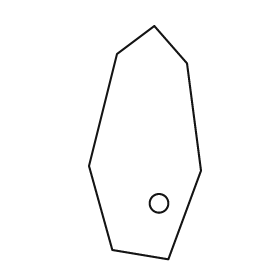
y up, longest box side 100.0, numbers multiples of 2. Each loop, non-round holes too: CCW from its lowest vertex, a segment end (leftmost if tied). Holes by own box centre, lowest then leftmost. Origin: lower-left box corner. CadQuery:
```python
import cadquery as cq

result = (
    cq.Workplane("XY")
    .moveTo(34.0, 0.0)
    .lineTo(48.0, 38.0)
    .lineTo(42.0, 84.0)
    .lineTo(28.0, 100.0)
    .lineTo(12.0, 88.0)
    .lineTo(0.0, 40.0)
    .lineTo(10.0, 4.0)
    .close()
    .moveTo(30.0, 24.0)
    .circle(4.0)
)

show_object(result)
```